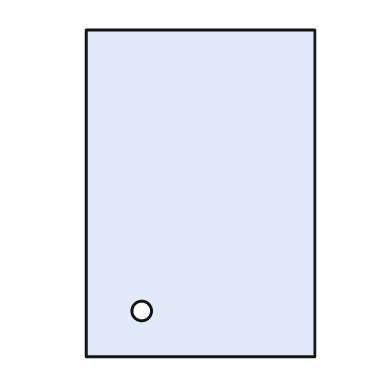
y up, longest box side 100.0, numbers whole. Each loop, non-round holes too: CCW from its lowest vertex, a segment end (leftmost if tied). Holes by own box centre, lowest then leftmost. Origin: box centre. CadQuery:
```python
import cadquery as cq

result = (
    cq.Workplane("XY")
    .moveTo(-35.0, -50.0)
    .lineTo(35.0, -50.0)
    .lineTo(35.0, 50.0)
    .lineTo(-35.0, 50.0)
    .close()
    .moveTo(-18.0, -36.0)
    .circle(3.0)
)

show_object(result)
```